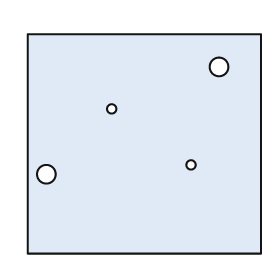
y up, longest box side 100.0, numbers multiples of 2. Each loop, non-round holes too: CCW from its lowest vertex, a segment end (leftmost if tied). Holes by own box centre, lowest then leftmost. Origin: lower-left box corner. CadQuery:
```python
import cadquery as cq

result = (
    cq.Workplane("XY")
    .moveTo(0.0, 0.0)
    .lineTo(100.0, 0.0)
    .lineTo(100.0, 94.0)
    .lineTo(0.0, 94.0)
    .close()
    .moveTo(8.0, 34.0)
    .circle(4.0)
    .moveTo(70.0, 38.0)
    .circle(2.0)
    .moveTo(36.0, 62.0)
    .circle(2.0)
    .moveTo(82.0, 80.0)
    .circle(4.0)
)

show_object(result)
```